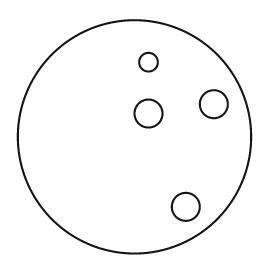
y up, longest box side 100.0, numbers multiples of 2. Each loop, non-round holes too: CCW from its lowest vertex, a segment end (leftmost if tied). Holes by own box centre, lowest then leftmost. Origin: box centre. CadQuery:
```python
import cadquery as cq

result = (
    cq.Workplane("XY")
    .moveTo(0.0, 0.0)
    .circle(50.0)
    .moveTo(22.0, -30.0)
    .circle(6.0)
    .moveTo(6.0, 10.0)
    .circle(6.0)
    .moveTo(34.0, 14.0)
    .circle(6.0)
    .moveTo(6.0, 32.0)
    .circle(4.0)
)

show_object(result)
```